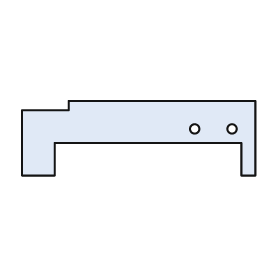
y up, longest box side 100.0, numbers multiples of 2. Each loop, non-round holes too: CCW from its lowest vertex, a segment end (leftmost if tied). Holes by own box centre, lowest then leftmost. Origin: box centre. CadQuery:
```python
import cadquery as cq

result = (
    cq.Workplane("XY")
    .moveTo(-50.0, -16.0)
    .lineTo(-36.0, -16.0)
    .lineTo(-36.0, -2.0)
    .lineTo(44.0, -2.0)
    .lineTo(44.0, -16.0)
    .lineTo(50.0, -16.0)
    .lineTo(50.0, 16.0)
    .lineTo(-30.0, 16.0)
    .lineTo(-30.0, 12.0)
    .lineTo(-50.0, 12.0)
    .close()
    .moveTo(24.0, 4.0)
    .circle(2.0)
    .moveTo(40.0, 4.0)
    .circle(2.0)
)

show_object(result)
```